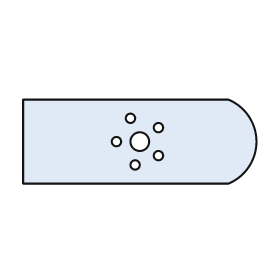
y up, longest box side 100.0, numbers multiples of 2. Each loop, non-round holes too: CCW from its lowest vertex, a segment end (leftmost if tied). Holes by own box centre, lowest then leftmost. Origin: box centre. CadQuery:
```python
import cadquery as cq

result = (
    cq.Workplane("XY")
    .moveTo(-50.0, -18.0)
    .lineTo(38.0, -18.0)
    .threePointArc((50.0, 0.0), (38.0, 18.0))
    .lineTo(-50.0, 18.0)
    .close()
    .moveTo(-2.0, -10.0)
    .circle(2.0)
    .moveTo(8.0, -6.0)
    .circle(2.0)
    .moveTo(-10.0, 0.0)
    .circle(2.0)
    .moveTo(0.0, 0.0)
    .circle(4.0)
    .moveTo(8.0, 6.0)
    .circle(2.0)
    .moveTo(-4.0, 10.0)
    .circle(2.0)
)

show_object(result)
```